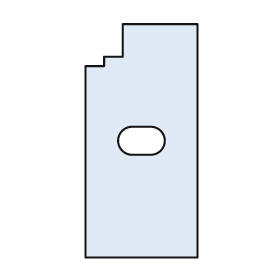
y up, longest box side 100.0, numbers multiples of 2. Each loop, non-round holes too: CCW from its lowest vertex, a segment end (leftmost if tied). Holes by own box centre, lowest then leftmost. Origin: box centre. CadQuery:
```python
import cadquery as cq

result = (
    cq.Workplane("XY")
    .moveTo(-24.0, -50.0)
    .lineTo(24.0, -50.0)
    .lineTo(24.0, 50.0)
    .lineTo(-8.0, 50.0)
    .lineTo(-8.0, 36.0)
    .lineTo(-16.0, 36.0)
    .lineTo(-16.0, 32.0)
    .lineTo(-24.0, 32.0)
    .close()
    .moveTo(-4.0, -6.0)
    .lineTo(4.0, -6.0)
    .threePointArc((10.0, 0.0), (4.0, 6.0))
    .lineTo(-4.0, 6.0)
    .threePointArc((-10.0, 0.0), (-4.0, -6.0))
    .close()
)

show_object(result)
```